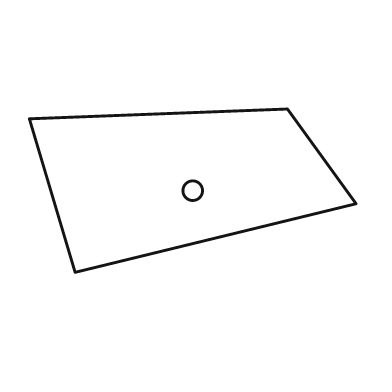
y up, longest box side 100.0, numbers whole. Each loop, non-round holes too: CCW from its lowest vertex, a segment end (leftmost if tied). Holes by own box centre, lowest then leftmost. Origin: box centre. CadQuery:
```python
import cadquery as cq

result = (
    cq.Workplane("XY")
    .moveTo(-36.0, -25.0)
    .lineTo(50.0, -4.0)
    .lineTo(29.0, 25.0)
    .lineTo(-50.0, 22.0)
    .close()
    .moveTo(0.0, 0.0)
    .circle(3.0)
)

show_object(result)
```